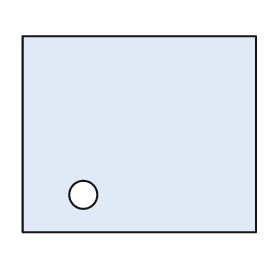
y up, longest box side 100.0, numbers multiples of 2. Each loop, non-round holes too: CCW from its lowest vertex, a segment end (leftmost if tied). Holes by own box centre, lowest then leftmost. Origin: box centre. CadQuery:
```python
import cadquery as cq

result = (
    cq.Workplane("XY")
    .moveTo(-50.0, -42.0)
    .lineTo(50.0, -42.0)
    .lineTo(50.0, 42.0)
    .lineTo(-50.0, 42.0)
    .close()
    .moveTo(-24.0, -26.0)
    .circle(6.0)
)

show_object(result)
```